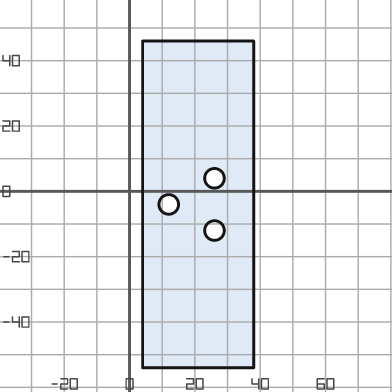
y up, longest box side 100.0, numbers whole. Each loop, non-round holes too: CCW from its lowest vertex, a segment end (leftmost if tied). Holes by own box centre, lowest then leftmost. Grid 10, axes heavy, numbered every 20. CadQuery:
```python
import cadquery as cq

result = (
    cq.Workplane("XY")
    .moveTo(4.0, -54.0)
    .lineTo(38.0, -54.0)
    .lineTo(38.0, 46.0)
    .lineTo(4.0, 46.0)
    .close()
    .moveTo(26.0, -12.0)
    .circle(3.0)
    .moveTo(12.0, -4.0)
    .circle(3.0)
    .moveTo(26.0, 4.0)
    .circle(3.0)
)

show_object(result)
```